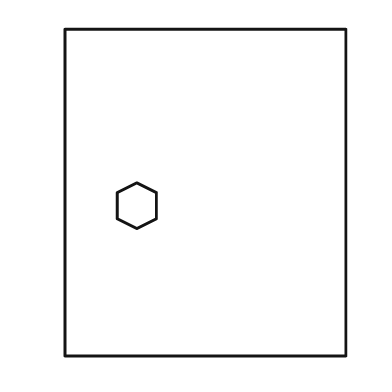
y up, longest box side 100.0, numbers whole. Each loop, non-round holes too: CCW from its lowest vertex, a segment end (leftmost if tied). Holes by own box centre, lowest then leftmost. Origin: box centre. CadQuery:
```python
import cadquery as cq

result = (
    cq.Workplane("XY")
    .moveTo(-43.0, -50.0)
    .lineTo(43.0, -50.0)
    .lineTo(43.0, 50.0)
    .lineTo(-43.0, 50.0)
    .close()
    .moveTo(-21.0, -11.0)
    .lineTo(-15.0, -8.0)
    .lineTo(-15.0, 0.0)
    .lineTo(-21.0, 3.0)
    .lineTo(-27.0, 0.0)
    .lineTo(-27.0, -8.0)
    .close()
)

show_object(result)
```